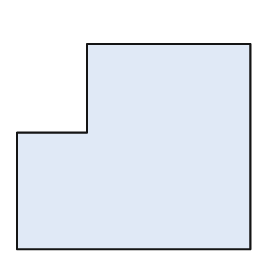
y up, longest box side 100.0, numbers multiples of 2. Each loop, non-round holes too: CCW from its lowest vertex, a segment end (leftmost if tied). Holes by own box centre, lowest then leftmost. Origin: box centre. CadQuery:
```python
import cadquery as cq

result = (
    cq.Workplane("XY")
    .moveTo(-50.0, -44.0)
    .lineTo(50.0, -44.0)
    .lineTo(50.0, 44.0)
    .lineTo(-20.0, 44.0)
    .lineTo(-20.0, 6.0)
    .lineTo(-50.0, 6.0)
    .close()
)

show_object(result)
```